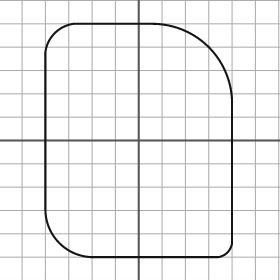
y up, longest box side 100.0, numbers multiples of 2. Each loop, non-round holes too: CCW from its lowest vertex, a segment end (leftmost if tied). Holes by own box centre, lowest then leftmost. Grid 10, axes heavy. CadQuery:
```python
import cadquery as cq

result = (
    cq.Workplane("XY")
    .moveTo(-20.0, -50.0)
    .lineTo(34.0, -50.0)
    .threePointArc((38.0, -48.0), (40.0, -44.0))
    .lineTo(40.0, 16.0)
    .threePointArc((30.0, 40.0), (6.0, 50.0))
    .lineTo(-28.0, 50.0)
    .threePointArc((-36.0, 46.0), (-40.0, 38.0))
    .lineTo(-40.0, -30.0)
    .threePointArc((-34.0, -44.0), (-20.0, -50.0))
    .close()
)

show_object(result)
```